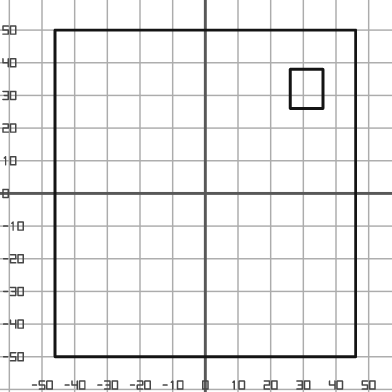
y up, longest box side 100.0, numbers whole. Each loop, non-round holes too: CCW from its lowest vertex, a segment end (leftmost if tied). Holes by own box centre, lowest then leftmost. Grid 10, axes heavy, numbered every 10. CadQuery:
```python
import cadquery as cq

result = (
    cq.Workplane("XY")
    .moveTo(-46.0, -50.0)
    .lineTo(46.0, -50.0)
    .lineTo(46.0, 50.0)
    .lineTo(-46.0, 50.0)
    .close()
    .moveTo(26.0, 26.0)
    .lineTo(36.0, 26.0)
    .lineTo(36.0, 38.0)
    .lineTo(26.0, 38.0)
    .close()
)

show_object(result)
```